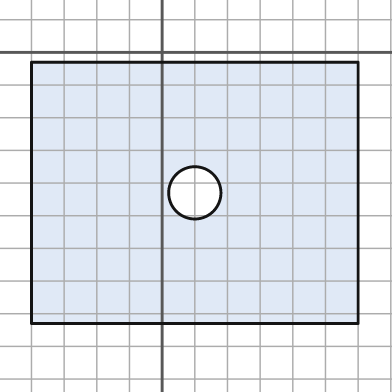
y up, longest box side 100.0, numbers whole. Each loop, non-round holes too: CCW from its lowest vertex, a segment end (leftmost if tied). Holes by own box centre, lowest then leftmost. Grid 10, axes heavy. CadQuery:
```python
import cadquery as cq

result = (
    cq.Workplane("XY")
    .moveTo(-40.0, -83.0)
    .lineTo(60.0, -83.0)
    .lineTo(60.0, -3.0)
    .lineTo(-40.0, -3.0)
    .close()
    .moveTo(10.0, -43.0)
    .circle(8.0)
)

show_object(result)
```